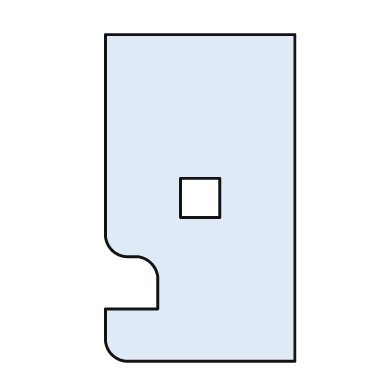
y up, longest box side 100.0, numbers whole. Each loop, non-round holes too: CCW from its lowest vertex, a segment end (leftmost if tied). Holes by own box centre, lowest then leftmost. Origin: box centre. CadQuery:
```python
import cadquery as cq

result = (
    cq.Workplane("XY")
    .moveTo(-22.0, -50.0)
    .lineTo(29.0, -50.0)
    .lineTo(29.0, 50.0)
    .lineTo(-29.0, 50.0)
    .lineTo(-29.0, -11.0)
    .threePointArc((-27.0, -16.0), (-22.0, -18.0))
    .lineTo(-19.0, -18.0)
    .threePointArc((-15.0, -20.0), (-13.0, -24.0))
    .lineTo(-13.0, -34.0)
    .lineTo(-29.0, -34.0)
    .lineTo(-29.0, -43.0)
    .threePointArc((-27.0, -48.0), (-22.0, -50.0))
    .close()
    .moveTo(-6.0, -6.0)
    .lineTo(6.0, -6.0)
    .lineTo(6.0, 6.0)
    .lineTo(-6.0, 6.0)
    .close()
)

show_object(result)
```